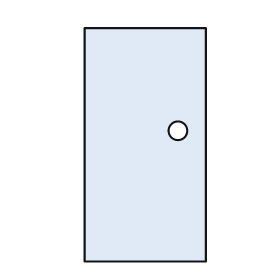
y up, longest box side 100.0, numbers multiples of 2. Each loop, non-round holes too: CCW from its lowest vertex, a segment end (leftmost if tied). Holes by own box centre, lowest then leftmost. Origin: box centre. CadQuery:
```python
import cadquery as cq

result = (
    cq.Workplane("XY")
    .moveTo(-26.0, -50.0)
    .lineTo(26.0, -50.0)
    .lineTo(26.0, 50.0)
    .lineTo(-26.0, 50.0)
    .close()
    .moveTo(14.0, 6.0)
    .circle(4.0)
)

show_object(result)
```